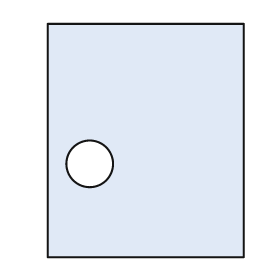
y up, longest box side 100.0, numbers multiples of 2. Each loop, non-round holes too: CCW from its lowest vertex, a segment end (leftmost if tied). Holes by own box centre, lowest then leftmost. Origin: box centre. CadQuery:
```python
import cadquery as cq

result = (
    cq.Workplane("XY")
    .moveTo(-42.0, -50.0)
    .lineTo(42.0, -50.0)
    .lineTo(42.0, 50.0)
    .lineTo(-42.0, 50.0)
    .close()
    .moveTo(-24.0, -10.0)
    .circle(10.0)
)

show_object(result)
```